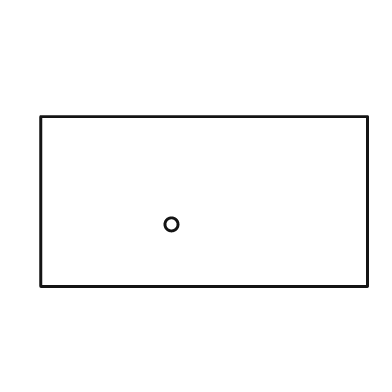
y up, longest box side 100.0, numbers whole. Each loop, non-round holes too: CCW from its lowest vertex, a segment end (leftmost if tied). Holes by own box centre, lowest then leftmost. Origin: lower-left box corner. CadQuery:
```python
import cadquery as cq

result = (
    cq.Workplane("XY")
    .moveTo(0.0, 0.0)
    .lineTo(100.0, 0.0)
    .lineTo(100.0, 52.0)
    .lineTo(0.0, 52.0)
    .close()
    .moveTo(40.0, 19.0)
    .circle(2.0)
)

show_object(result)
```